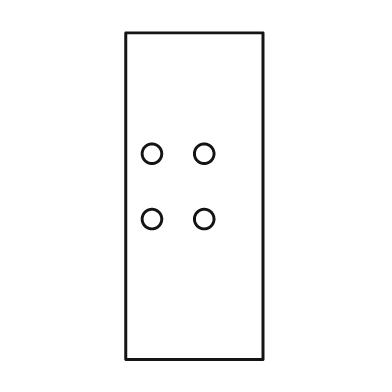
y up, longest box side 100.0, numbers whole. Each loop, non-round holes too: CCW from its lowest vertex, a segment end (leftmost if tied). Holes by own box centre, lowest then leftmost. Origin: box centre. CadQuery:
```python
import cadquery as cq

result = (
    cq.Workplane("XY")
    .moveTo(-21.0, -50.0)
    .lineTo(21.0, -50.0)
    .lineTo(21.0, 50.0)
    .lineTo(-21.0, 50.0)
    .close()
    .moveTo(-13.0, -7.0)
    .circle(3.0)
    .moveTo(3.0, -7.0)
    .circle(3.0)
    .moveTo(-13.0, 13.0)
    .circle(3.0)
    .moveTo(3.0, 13.0)
    .circle(3.0)
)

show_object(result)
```